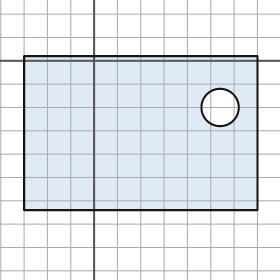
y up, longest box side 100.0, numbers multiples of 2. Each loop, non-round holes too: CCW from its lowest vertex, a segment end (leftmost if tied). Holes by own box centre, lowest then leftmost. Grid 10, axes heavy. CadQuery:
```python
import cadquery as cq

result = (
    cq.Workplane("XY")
    .moveTo(-30.0, -64.0)
    .lineTo(70.0, -64.0)
    .lineTo(70.0, 2.0)
    .lineTo(-30.0, 2.0)
    .close()
    .moveTo(54.0, -20.0)
    .circle(8.0)
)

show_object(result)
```